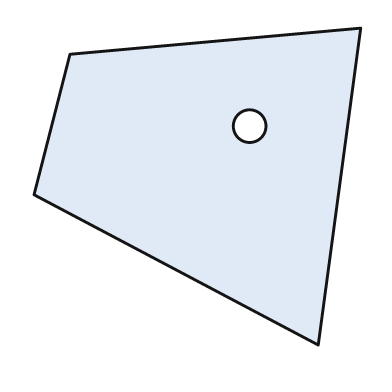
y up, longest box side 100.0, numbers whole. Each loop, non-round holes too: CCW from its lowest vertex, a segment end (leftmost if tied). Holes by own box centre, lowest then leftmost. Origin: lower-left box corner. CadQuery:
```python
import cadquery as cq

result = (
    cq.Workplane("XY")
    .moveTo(87.0, 0.0)
    .lineTo(100.0, 97.0)
    .lineTo(11.0, 89.0)
    .lineTo(0.0, 46.0)
    .close()
    .moveTo(66.0, 67.0)
    .circle(5.0)
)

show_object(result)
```